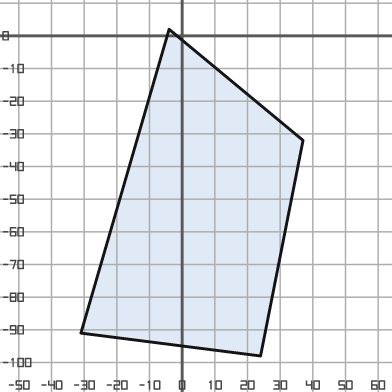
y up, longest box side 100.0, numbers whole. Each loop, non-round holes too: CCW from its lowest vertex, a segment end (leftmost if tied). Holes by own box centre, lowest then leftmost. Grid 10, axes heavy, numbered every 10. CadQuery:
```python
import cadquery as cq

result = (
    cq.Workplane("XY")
    .moveTo(24.0, -98.0)
    .lineTo(37.0, -32.0)
    .lineTo(-4.0, 2.0)
    .lineTo(-31.0, -91.0)
    .close()
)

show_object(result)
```